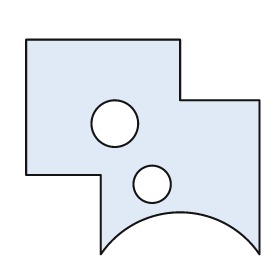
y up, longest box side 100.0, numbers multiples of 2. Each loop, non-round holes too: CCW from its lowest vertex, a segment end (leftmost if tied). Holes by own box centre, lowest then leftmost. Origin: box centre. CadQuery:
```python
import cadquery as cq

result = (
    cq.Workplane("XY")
    .moveTo(-18.0, -46.0)
    .threePointArc((16.0, -28.0), (50.0, -46.0))
    .lineTo(50.0, 20.0)
    .lineTo(16.0, 20.0)
    .lineTo(16.0, 46.0)
    .lineTo(-50.0, 46.0)
    .lineTo(-50.0, -12.0)
    .lineTo(-18.0, -12.0)
    .close()
    .moveTo(4.0, -16.0)
    .circle(8.0)
    .moveTo(-12.0, 10.0)
    .circle(10.0)
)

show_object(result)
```